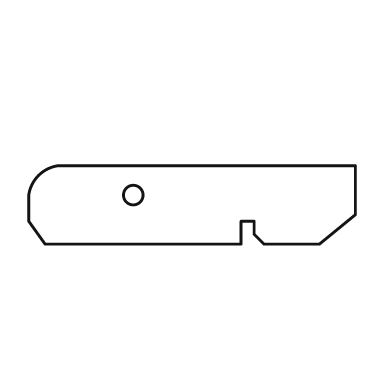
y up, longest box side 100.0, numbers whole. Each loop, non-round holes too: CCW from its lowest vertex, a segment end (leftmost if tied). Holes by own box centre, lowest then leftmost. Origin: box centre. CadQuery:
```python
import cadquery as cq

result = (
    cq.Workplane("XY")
    .moveTo(-45.0, -12.0)
    .lineTo(15.0, -12.0)
    .lineTo(15.0, -5.0)
    .lineTo(19.0, -5.0)
    .lineTo(19.0, -9.0)
    .lineTo(22.0, -12.0)
    .lineTo(39.0, -12.0)
    .lineTo(50.0, -3.0)
    .lineTo(50.0, 12.0)
    .lineTo(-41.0, 12.0)
    .threePointArc((-47.0, 9.0), (-50.0, 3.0))
    .lineTo(-50.0, -5.0)
    .close()
    .moveTo(-18.0, 3.0)
    .circle(3.0)
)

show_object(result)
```